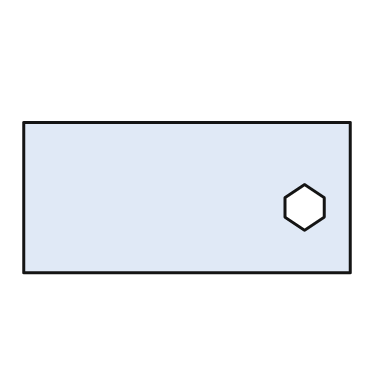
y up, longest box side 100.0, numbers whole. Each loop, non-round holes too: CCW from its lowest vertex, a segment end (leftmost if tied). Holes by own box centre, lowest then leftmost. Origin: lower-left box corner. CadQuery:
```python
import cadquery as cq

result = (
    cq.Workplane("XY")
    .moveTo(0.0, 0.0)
    .lineTo(100.0, 0.0)
    .lineTo(100.0, 46.0)
    .lineTo(0.0, 46.0)
    .close()
    .moveTo(86.0, 13.0)
    .lineTo(92.0, 17.0)
    .lineTo(92.0, 23.0)
    .lineTo(86.0, 27.0)
    .lineTo(80.0, 23.0)
    .lineTo(80.0, 17.0)
    .close()
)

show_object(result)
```